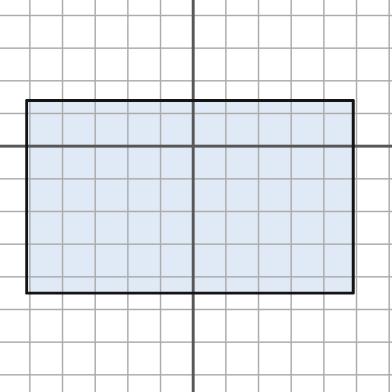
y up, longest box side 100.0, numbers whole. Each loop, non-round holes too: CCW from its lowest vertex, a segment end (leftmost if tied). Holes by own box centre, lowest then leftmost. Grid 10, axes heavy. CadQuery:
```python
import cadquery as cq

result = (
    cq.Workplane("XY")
    .moveTo(-51.0, -45.0)
    .lineTo(49.0, -45.0)
    .lineTo(49.0, 14.0)
    .lineTo(-51.0, 14.0)
    .close()
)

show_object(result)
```